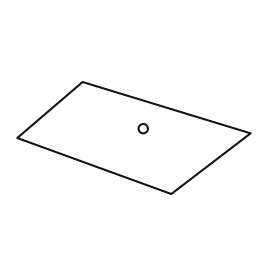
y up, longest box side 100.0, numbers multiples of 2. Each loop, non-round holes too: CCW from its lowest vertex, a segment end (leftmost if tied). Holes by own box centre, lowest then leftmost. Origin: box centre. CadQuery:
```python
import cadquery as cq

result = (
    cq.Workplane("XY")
    .moveTo(16.0, -24.0)
    .lineTo(50.0, 2.0)
    .lineTo(-22.0, 24.0)
    .lineTo(-50.0, 0.0)
    .close()
    .moveTo(4.0, 4.0)
    .circle(2.0)
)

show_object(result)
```